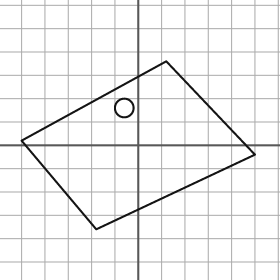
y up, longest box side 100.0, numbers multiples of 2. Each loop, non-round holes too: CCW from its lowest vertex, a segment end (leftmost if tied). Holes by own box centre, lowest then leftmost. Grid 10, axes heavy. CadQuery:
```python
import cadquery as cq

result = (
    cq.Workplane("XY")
    .moveTo(-18.0, -36.0)
    .lineTo(50.0, -4.0)
    .lineTo(12.0, 36.0)
    .lineTo(-50.0, 2.0)
    .close()
    .moveTo(-6.0, 16.0)
    .circle(4.0)
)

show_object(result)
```